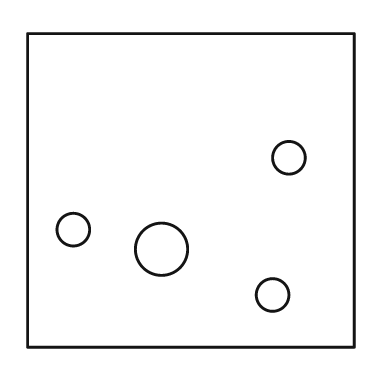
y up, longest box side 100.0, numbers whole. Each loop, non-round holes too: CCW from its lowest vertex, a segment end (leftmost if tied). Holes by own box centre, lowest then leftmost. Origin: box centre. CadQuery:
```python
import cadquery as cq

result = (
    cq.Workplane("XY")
    .moveTo(-50.0, -48.0)
    .lineTo(50.0, -48.0)
    .lineTo(50.0, 48.0)
    .lineTo(-50.0, 48.0)
    .close()
    .moveTo(25.0, -32.0)
    .circle(5.0)
    .moveTo(-9.0, -18.0)
    .circle(8.0)
    .moveTo(-36.0, -12.0)
    .circle(5.0)
    .moveTo(30.0, 10.0)
    .circle(5.0)
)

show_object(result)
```